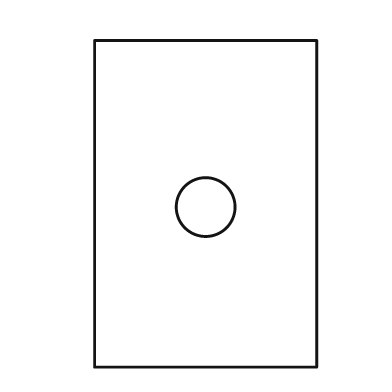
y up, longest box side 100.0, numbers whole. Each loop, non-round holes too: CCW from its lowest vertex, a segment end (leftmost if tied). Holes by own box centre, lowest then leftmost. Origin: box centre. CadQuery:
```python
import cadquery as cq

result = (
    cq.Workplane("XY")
    .moveTo(-34.0, -50.0)
    .lineTo(34.0, -50.0)
    .lineTo(34.0, 50.0)
    .lineTo(-34.0, 50.0)
    .close()
    .moveTo(0.0, -1.0)
    .circle(9.0)
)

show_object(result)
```